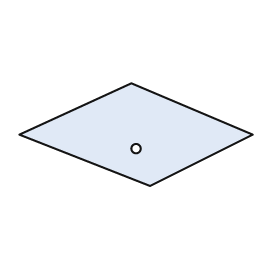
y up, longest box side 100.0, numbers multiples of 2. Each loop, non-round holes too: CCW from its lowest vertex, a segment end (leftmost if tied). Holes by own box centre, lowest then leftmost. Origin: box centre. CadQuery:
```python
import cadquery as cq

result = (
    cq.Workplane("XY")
    .moveTo(6.0, -22.0)
    .lineTo(50.0, 0.0)
    .lineTo(-2.0, 22.0)
    .lineTo(-50.0, 0.0)
    .close()
    .moveTo(0.0, -6.0)
    .circle(2.0)
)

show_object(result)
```